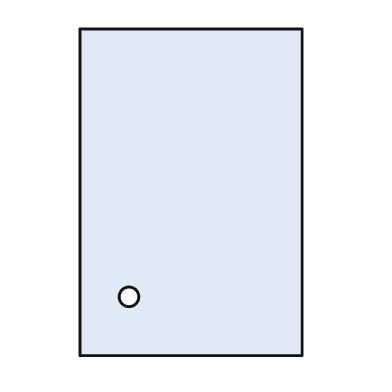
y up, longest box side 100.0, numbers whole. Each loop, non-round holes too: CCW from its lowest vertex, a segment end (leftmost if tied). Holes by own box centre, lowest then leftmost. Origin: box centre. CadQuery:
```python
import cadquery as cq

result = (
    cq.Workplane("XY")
    .moveTo(-34.0, -50.0)
    .lineTo(34.0, -50.0)
    .lineTo(34.0, 50.0)
    .lineTo(-34.0, 50.0)
    .close()
    .moveTo(-19.0, -32.0)
    .circle(3.0)
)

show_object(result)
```